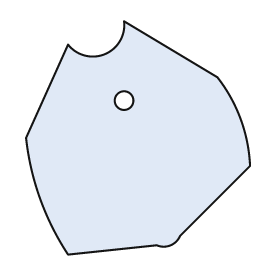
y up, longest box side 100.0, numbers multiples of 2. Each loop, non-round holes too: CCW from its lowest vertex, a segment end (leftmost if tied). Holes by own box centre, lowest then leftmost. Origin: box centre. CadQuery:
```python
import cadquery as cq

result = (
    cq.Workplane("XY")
    .moveTo(-30.0, -50.0)
    .lineTo(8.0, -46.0)
    .threePointArc((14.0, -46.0), (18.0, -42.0))
    .lineTo(48.0, -12.0)
    .threePointArc((44.0, 8.0), (34.0, 26.0))
    .lineTo(-6.0, 50.0)
    .threePointArc((-14.0, 36.0), (-30.0, 40.0))
    .lineTo(-48.0, 0.0)
    .threePointArc((-42.0, -26.0), (-30.0, -50.0))
    .close()
    .moveTo(-6.0, 16.0)
    .circle(4.0)
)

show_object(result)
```